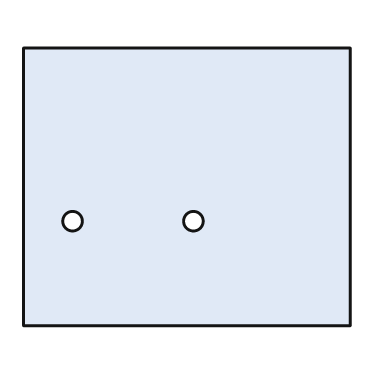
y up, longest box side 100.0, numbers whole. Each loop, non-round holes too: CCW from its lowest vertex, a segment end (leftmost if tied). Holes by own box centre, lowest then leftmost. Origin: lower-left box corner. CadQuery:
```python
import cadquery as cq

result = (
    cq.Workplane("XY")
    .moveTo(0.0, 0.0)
    .lineTo(100.0, 0.0)
    .lineTo(100.0, 85.0)
    .lineTo(0.0, 85.0)
    .close()
    .moveTo(15.0, 32.0)
    .circle(3.0)
    .moveTo(52.0, 32.0)
    .circle(3.0)
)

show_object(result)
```